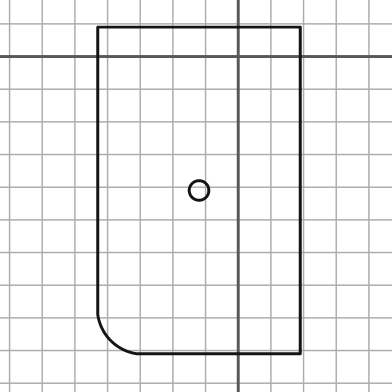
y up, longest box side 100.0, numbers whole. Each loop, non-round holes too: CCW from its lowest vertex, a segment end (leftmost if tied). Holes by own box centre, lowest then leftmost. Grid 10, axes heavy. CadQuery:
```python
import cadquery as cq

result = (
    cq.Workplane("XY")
    .moveTo(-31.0, -91.0)
    .lineTo(19.0, -91.0)
    .lineTo(19.0, 9.0)
    .lineTo(-43.0, 9.0)
    .lineTo(-43.0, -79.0)
    .threePointArc((-39.0, -87.0), (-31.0, -91.0))
    .close()
    .moveTo(-12.0, -41.0)
    .circle(3.0)
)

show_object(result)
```